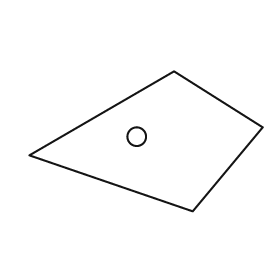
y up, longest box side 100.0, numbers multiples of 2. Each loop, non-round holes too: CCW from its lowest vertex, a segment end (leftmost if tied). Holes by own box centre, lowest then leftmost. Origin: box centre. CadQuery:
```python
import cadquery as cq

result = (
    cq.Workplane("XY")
    .moveTo(20.0, -30.0)
    .lineTo(50.0, 6.0)
    .lineTo(12.0, 30.0)
    .lineTo(-50.0, -6.0)
    .close()
    .moveTo(-4.0, 2.0)
    .circle(4.0)
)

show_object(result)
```